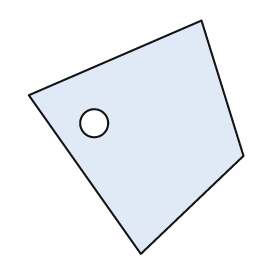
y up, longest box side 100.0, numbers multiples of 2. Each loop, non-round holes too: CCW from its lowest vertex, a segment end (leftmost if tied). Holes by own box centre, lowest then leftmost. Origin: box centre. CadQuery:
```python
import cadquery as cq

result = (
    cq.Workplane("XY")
    .moveTo(2.0, -50.0)
    .lineTo(46.0, -8.0)
    .lineTo(28.0, 50.0)
    .lineTo(-46.0, 18.0)
    .close()
    .moveTo(-18.0, 6.0)
    .circle(6.0)
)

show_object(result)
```